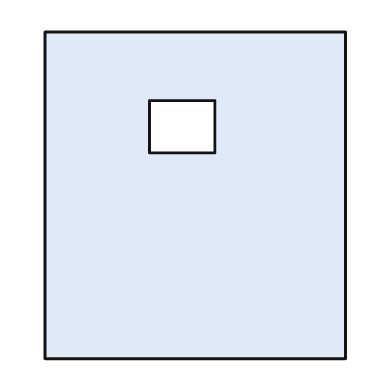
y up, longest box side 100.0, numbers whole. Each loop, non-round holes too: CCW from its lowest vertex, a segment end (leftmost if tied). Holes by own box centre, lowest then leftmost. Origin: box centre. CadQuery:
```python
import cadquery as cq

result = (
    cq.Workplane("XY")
    .moveTo(-46.0, -50.0)
    .lineTo(46.0, -50.0)
    .lineTo(46.0, 50.0)
    .lineTo(-46.0, 50.0)
    .close()
    .moveTo(-14.0, 13.0)
    .lineTo(6.0, 13.0)
    .lineTo(6.0, 29.0)
    .lineTo(-14.0, 29.0)
    .close()
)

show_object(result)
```